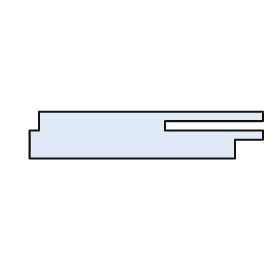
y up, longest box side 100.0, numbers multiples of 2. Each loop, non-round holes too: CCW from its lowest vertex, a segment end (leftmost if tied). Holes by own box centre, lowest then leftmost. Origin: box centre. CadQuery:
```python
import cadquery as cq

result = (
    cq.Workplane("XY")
    .moveTo(-50.0, -10.0)
    .lineTo(38.0, -10.0)
    .lineTo(38.0, -2.0)
    .lineTo(50.0, -2.0)
    .lineTo(50.0, 2.0)
    .lineTo(8.0, 2.0)
    .lineTo(8.0, 6.0)
    .lineTo(50.0, 6.0)
    .lineTo(50.0, 10.0)
    .lineTo(-46.0, 10.0)
    .lineTo(-46.0, 2.0)
    .lineTo(-50.0, 2.0)
    .close()
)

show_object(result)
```